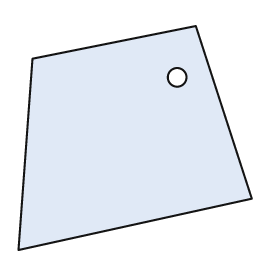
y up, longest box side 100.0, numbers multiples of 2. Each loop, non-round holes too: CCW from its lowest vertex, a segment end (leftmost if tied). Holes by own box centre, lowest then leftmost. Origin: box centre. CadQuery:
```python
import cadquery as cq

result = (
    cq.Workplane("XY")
    .moveTo(-50.0, -48.0)
    .lineTo(50.0, -26.0)
    .lineTo(26.0, 48.0)
    .lineTo(-44.0, 34.0)
    .close()
    .moveTo(18.0, 26.0)
    .circle(4.0)
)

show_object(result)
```